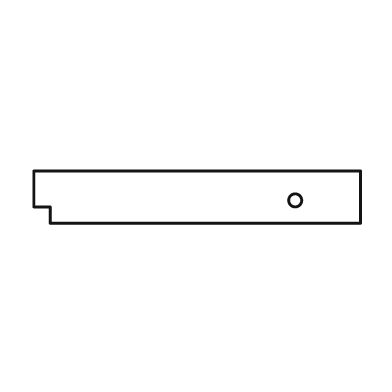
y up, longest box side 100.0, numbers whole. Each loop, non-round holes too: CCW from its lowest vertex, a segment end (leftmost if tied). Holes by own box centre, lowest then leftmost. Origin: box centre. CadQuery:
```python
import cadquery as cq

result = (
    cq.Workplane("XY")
    .moveTo(-45.0, -8.0)
    .lineTo(50.0, -8.0)
    .lineTo(50.0, 8.0)
    .lineTo(-50.0, 8.0)
    .lineTo(-50.0, -3.0)
    .lineTo(-45.0, -3.0)
    .close()
    .moveTo(30.0, -1.0)
    .circle(2.0)
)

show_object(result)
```